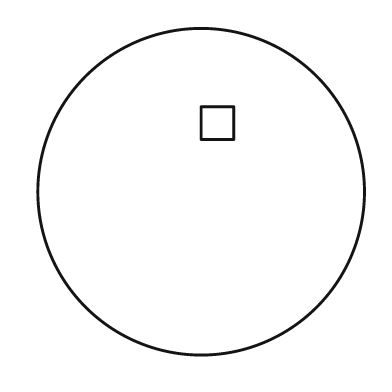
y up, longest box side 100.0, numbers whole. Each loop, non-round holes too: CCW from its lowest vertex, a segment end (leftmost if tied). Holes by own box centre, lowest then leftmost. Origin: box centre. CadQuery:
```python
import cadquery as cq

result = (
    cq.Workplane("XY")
    .moveTo(0.0, 0.0)
    .circle(50.0)
    .moveTo(0.0, 16.0)
    .lineTo(10.0, 16.0)
    .lineTo(10.0, 26.0)
    .lineTo(0.0, 26.0)
    .close()
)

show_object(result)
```